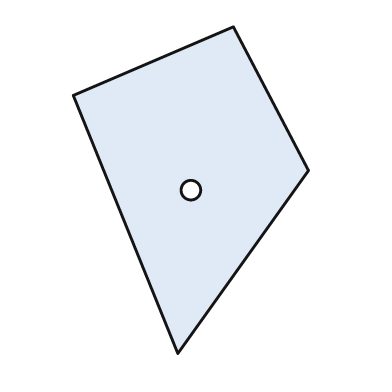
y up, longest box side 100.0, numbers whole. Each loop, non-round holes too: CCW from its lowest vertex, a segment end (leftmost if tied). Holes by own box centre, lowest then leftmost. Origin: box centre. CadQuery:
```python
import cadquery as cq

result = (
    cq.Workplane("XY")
    .moveTo(-4.0, -50.0)
    .lineTo(36.0, 6.0)
    .lineTo(13.0, 50.0)
    .lineTo(-36.0, 29.0)
    .close()
    .moveTo(0.0, 0.0)
    .circle(3.0)
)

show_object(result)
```